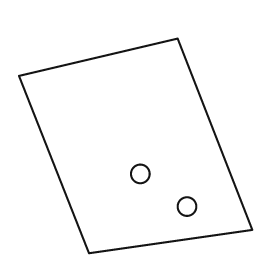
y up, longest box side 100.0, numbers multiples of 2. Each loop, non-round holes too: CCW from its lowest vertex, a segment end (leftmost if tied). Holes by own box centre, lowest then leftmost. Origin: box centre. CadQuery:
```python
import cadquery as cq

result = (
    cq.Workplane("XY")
    .moveTo(-20.0, -46.0)
    .lineTo(50.0, -36.0)
    .lineTo(18.0, 46.0)
    .lineTo(-50.0, 30.0)
    .close()
    .moveTo(22.0, -26.0)
    .circle(4.0)
    .moveTo(2.0, -12.0)
    .circle(4.0)
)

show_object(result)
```